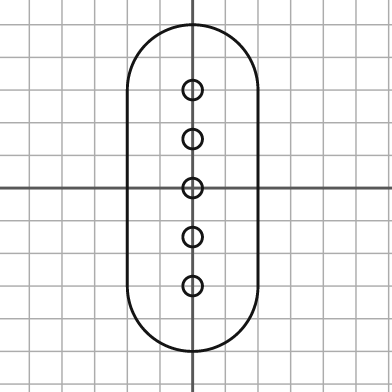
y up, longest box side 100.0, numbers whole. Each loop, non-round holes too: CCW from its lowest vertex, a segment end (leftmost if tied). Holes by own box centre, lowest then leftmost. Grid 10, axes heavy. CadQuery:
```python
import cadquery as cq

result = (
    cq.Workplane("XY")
    .moveTo(-20.0, -30.0)
    .threePointArc((0.0, -50.0), (20.0, -30.0))
    .lineTo(20.0, 30.0)
    .threePointArc((0.0, 50.0), (-20.0, 30.0))
    .close()
    .moveTo(0.0, -30.0)
    .circle(3.0)
    .moveTo(0.0, -15.0)
    .circle(3.0)
    .moveTo(0.0, 0.0)
    .circle(3.0)
    .moveTo(0.0, 15.0)
    .circle(3.0)
    .moveTo(0.0, 30.0)
    .circle(3.0)
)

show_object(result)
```